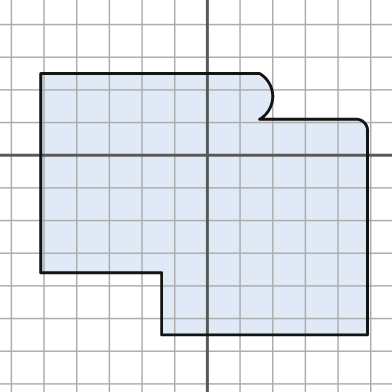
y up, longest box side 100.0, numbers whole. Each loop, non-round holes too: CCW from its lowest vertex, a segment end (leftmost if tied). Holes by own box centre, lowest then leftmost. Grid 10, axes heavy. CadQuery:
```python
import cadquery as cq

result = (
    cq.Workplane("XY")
    .moveTo(-14.0, -55.0)
    .lineTo(49.0, -55.0)
    .lineTo(49.0, 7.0)
    .threePointArc((48.0, 10.0), (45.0, 11.0))
    .lineTo(16.0, 11.0)
    .threePointArc((20.0, 18.0), (16.0, 25.0))
    .lineTo(-51.0, 25.0)
    .lineTo(-51.0, -36.0)
    .lineTo(-14.0, -36.0)
    .close()
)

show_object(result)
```